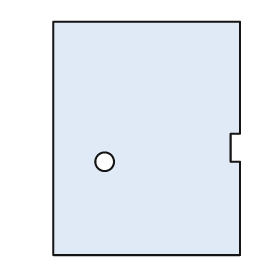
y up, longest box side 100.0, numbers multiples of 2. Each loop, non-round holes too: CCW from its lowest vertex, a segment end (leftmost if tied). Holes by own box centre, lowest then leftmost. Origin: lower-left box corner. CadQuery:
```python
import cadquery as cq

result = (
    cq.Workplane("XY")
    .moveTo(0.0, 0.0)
    .lineTo(80.0, 0.0)
    .lineTo(80.0, 40.0)
    .lineTo(76.0, 40.0)
    .lineTo(76.0, 52.0)
    .lineTo(80.0, 52.0)
    .lineTo(80.0, 100.0)
    .lineTo(0.0, 100.0)
    .close()
    .moveTo(22.0, 40.0)
    .circle(4.0)
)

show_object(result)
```